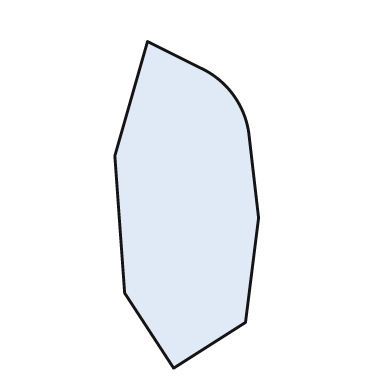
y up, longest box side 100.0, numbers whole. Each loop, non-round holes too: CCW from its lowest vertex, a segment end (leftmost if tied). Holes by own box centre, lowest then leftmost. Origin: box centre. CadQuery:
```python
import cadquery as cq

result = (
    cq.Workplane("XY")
    .moveTo(-4.0, -50.0)
    .lineTo(18.0, -36.0)
    .lineTo(22.0, -4.0)
    .lineTo(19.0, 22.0)
    .threePointArc((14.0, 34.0), (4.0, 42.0))
    .lineTo(-12.0, 50.0)
    .lineTo(-22.0, 15.0)
    .lineTo(-19.0, -27.0)
    .close()
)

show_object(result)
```